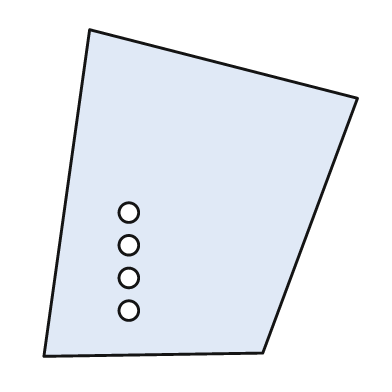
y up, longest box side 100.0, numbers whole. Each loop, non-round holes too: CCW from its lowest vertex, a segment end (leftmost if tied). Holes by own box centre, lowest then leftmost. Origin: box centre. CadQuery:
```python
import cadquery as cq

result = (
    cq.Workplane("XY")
    .moveTo(-48.0, -50.0)
    .lineTo(19.0, -49.0)
    .lineTo(48.0, 29.0)
    .lineTo(-34.0, 50.0)
    .close()
    .moveTo(-22.0, -36.0)
    .circle(3.0)
    .moveTo(-22.0, -26.0)
    .circle(3.0)
    .moveTo(-22.0, -16.0)
    .circle(3.0)
    .moveTo(-22.0, -6.0)
    .circle(3.0)
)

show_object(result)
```